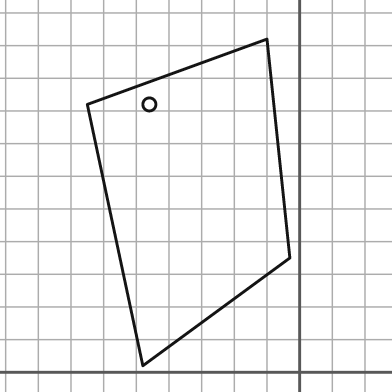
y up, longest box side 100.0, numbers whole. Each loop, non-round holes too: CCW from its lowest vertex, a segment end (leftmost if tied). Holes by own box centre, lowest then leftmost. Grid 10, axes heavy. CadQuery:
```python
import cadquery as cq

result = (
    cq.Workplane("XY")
    .moveTo(-48.0, 2.0)
    .lineTo(-3.0, 35.0)
    .lineTo(-10.0, 102.0)
    .lineTo(-65.0, 82.0)
    .close()
    .moveTo(-46.0, 82.0)
    .circle(2.0)
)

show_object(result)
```